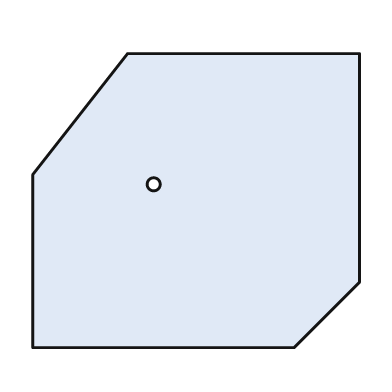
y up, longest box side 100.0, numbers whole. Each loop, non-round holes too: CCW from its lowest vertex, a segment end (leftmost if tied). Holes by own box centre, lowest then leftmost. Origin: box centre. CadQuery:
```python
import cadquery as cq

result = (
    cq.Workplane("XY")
    .moveTo(-50.0, -45.0)
    .lineTo(30.0, -45.0)
    .lineTo(50.0, -25.0)
    .lineTo(50.0, 45.0)
    .lineTo(-21.0, 45.0)
    .lineTo(-50.0, 8.0)
    .close()
    .moveTo(-13.0, 5.0)
    .circle(2.0)
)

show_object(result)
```